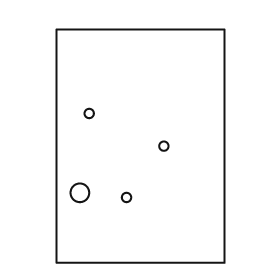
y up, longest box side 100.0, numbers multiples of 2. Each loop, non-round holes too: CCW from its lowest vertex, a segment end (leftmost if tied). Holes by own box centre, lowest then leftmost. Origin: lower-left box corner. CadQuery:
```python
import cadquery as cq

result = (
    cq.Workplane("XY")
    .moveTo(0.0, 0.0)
    .lineTo(72.0, 0.0)
    .lineTo(72.0, 100.0)
    .lineTo(0.0, 100.0)
    .close()
    .moveTo(30.0, 28.0)
    .circle(2.0)
    .moveTo(10.0, 30.0)
    .circle(4.0)
    .moveTo(46.0, 50.0)
    .circle(2.0)
    .moveTo(14.0, 64.0)
    .circle(2.0)
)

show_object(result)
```